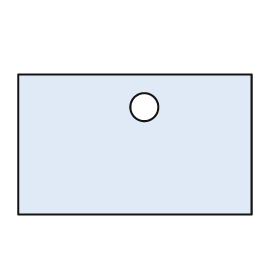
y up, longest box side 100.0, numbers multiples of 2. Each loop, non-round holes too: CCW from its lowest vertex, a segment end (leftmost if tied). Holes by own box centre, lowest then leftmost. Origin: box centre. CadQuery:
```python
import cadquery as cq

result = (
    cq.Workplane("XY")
    .moveTo(-50.0, -30.0)
    .lineTo(50.0, -30.0)
    .lineTo(50.0, 30.0)
    .lineTo(-50.0, 30.0)
    .close()
    .moveTo(4.0, 16.0)
    .circle(6.0)
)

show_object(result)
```